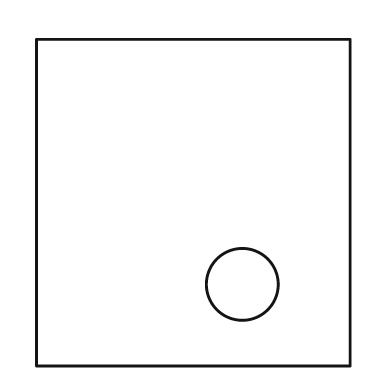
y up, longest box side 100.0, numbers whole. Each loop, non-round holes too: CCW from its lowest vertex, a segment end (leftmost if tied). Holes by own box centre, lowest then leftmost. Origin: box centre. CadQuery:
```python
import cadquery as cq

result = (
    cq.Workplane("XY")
    .moveTo(-48.0, -50.0)
    .lineTo(48.0, -50.0)
    .lineTo(48.0, 50.0)
    .lineTo(-48.0, 50.0)
    .close()
    .moveTo(15.0, -25.0)
    .circle(11.0)
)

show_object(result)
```